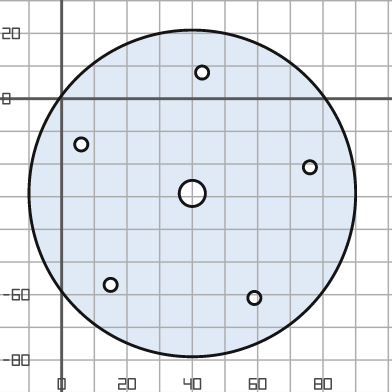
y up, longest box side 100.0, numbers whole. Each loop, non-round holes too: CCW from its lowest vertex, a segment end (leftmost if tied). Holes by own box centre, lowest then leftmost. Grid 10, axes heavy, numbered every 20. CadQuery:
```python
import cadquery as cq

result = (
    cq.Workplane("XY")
    .moveTo(40.0, -29.0)
    .circle(50.0)
    .moveTo(59.0, -61.0)
    .circle(2.0)
    .moveTo(15.0, -57.0)
    .circle(2.0)
    .moveTo(40.0, -29.0)
    .circle(4.0)
    .moveTo(76.0, -21.0)
    .circle(2.0)
    .moveTo(6.0, -14.0)
    .circle(2.0)
    .moveTo(43.0, 8.0)
    .circle(2.0)
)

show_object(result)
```